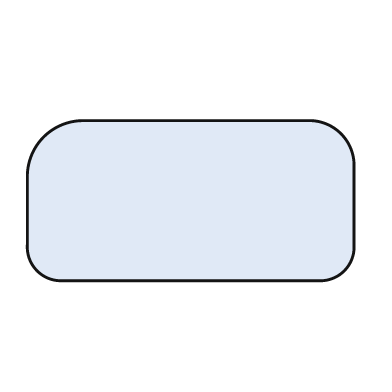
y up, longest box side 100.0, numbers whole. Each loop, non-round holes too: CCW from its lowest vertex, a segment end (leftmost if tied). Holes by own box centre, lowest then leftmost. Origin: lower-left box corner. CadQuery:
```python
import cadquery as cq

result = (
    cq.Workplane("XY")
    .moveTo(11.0, 0.0)
    .lineTo(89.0, 0.0)
    .threePointArc((97.0, 3.0), (100.0, 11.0))
    .lineTo(100.0, 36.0)
    .threePointArc((96.0, 45.0), (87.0, 49.0))
    .lineTo(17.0, 49.0)
    .threePointArc((5.0, 44.0), (0.0, 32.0))
    .lineTo(0.0, 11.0)
    .threePointArc((3.0, 3.0), (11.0, 0.0))
    .close()
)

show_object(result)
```